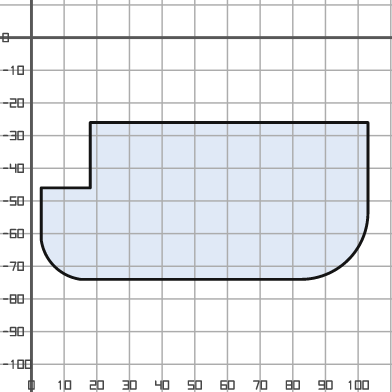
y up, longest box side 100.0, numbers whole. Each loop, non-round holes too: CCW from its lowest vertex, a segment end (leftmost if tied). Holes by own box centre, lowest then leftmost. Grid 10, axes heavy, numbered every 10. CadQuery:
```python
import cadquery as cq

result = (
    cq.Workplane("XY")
    .moveTo(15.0, -74.0)
    .lineTo(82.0, -74.0)
    .threePointArc((97.0, -68.0), (103.0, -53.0))
    .lineTo(103.0, -26.0)
    .lineTo(18.0, -26.0)
    .lineTo(18.0, -46.0)
    .lineTo(3.0, -46.0)
    .lineTo(3.0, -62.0)
    .threePointArc((7.0, -70.0), (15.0, -74.0))
    .close()
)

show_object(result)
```